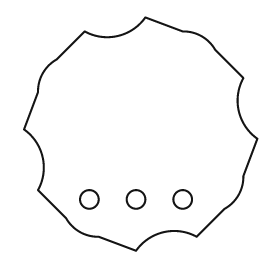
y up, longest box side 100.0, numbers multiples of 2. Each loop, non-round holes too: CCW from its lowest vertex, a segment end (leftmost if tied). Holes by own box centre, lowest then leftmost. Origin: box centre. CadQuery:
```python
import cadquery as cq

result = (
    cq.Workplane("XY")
    .moveTo(-2.0, -50.0)
    .threePointArc((10.0, -42.0), (24.0, -44.0))
    .lineTo(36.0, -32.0)
    .threePointArc((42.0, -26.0), (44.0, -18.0))
    .lineTo(50.0, -2.0)
    .threePointArc((42.0, 10.0), (44.0, 24.0))
    .lineTo(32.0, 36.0)
    .threePointArc((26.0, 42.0), (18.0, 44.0))
    .lineTo(2.0, 50.0)
    .threePointArc((-10.0, 42.0), (-24.0, 44.0))
    .lineTo(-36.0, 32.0)
    .threePointArc((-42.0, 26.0), (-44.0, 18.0))
    .lineTo(-50.0, 2.0)
    .threePointArc((-42.0, -10.0), (-44.0, -24.0))
    .lineTo(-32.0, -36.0)
    .threePointArc((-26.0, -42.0), (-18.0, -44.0))
    .close()
    .moveTo(-22.0, -28.0)
    .circle(4.0)
    .moveTo(-2.0, -28.0)
    .circle(4.0)
    .moveTo(18.0, -28.0)
    .circle(4.0)
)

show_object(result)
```